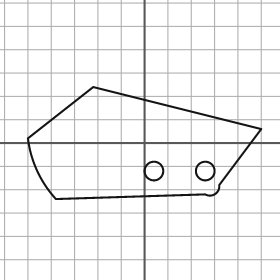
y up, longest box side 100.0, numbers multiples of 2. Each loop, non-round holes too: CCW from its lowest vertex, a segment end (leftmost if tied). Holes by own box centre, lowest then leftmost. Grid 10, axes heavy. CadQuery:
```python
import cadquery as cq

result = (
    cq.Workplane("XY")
    .moveTo(-38.0, -24.0)
    .lineTo(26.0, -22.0)
    .threePointArc((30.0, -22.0), (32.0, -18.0))
    .lineTo(50.0, 6.0)
    .lineTo(-22.0, 24.0)
    .lineTo(-50.0, 2.0)
    .threePointArc((-46.0, -12.0), (-38.0, -24.0))
    .close()
    .moveTo(4.0, -12.0)
    .circle(4.0)
    .moveTo(26.0, -12.0)
    .circle(4.0)
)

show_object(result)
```